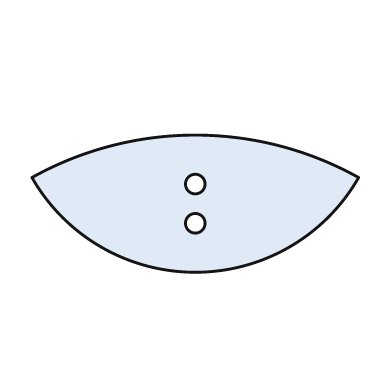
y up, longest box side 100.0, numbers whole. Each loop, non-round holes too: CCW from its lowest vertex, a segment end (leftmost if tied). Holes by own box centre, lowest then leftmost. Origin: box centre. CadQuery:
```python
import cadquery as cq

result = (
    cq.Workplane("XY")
    .moveTo(-50.0, 8.0)
    .threePointArc((0.0, -21.0), (50.0, 8.0))
    .threePointArc((0.0, 21.0), (-50.0, 8.0))
    .close()
    .moveTo(0.0, -6.0)
    .circle(3.0)
    .moveTo(0.0, 6.0)
    .circle(3.0)
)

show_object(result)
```